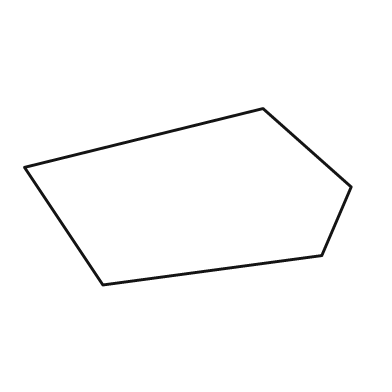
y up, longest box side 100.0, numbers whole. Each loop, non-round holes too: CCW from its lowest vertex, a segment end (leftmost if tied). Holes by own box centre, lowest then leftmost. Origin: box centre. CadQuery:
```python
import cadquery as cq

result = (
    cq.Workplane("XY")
    .moveTo(-26.0, -27.0)
    .lineTo(41.0, -18.0)
    .lineTo(50.0, 3.0)
    .lineTo(23.0, 27.0)
    .lineTo(-50.0, 9.0)
    .close()
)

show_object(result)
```